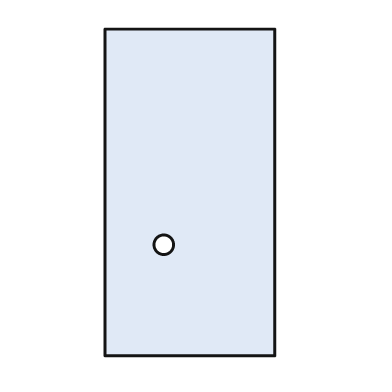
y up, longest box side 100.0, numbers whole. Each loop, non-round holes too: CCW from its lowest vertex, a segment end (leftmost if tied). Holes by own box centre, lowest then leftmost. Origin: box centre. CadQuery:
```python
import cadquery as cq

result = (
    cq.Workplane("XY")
    .moveTo(-26.0, -50.0)
    .lineTo(26.0, -50.0)
    .lineTo(26.0, 50.0)
    .lineTo(-26.0, 50.0)
    .close()
    .moveTo(-8.0, -16.0)
    .circle(3.0)
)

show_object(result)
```